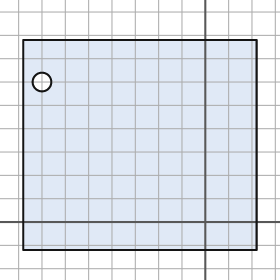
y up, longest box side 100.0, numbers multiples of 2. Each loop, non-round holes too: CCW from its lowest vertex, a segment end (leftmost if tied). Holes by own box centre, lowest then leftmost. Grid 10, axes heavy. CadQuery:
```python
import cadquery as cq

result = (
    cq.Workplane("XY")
    .moveTo(-78.0, -12.0)
    .lineTo(22.0, -12.0)
    .lineTo(22.0, 78.0)
    .lineTo(-78.0, 78.0)
    .close()
    .moveTo(-70.0, 60.0)
    .circle(4.0)
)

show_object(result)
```